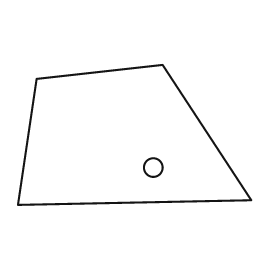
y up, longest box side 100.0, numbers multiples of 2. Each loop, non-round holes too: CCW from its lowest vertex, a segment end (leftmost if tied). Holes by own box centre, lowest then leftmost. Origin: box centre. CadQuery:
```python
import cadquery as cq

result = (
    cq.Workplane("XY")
    .moveTo(-50.0, -30.0)
    .lineTo(50.0, -28.0)
    .lineTo(12.0, 30.0)
    .lineTo(-42.0, 24.0)
    .close()
    .moveTo(8.0, -14.0)
    .circle(4.0)
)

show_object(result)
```